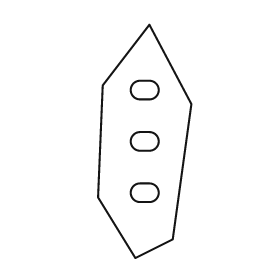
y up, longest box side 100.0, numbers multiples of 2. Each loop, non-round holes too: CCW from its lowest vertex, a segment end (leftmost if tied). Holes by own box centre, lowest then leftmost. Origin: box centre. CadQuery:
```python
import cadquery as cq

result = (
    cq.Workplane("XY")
    .moveTo(-4.0, -50.0)
    .lineTo(12.0, -42.0)
    .lineTo(20.0, 16.0)
    .lineTo(2.0, 50.0)
    .lineTo(-18.0, 24.0)
    .lineTo(-20.0, -24.0)
    .close()
    .moveTo(-2.0, -26.0)
    .lineTo(2.0, -26.0)
    .threePointArc((6.0, -22.0), (2.0, -18.0))
    .lineTo(-2.0, -18.0)
    .threePointArc((-6.0, -22.0), (-2.0, -26.0))
    .close()
    .moveTo(-2.0, -4.0)
    .lineTo(2.0, -4.0)
    .threePointArc((6.0, 0.0), (2.0, 4.0))
    .lineTo(-2.0, 4.0)
    .threePointArc((-6.0, 0.0), (-2.0, -4.0))
    .close()
    .moveTo(-2.0, 18.0)
    .lineTo(2.0, 18.0)
    .threePointArc((6.0, 22.0), (2.0, 26.0))
    .lineTo(-2.0, 26.0)
    .threePointArc((-6.0, 22.0), (-2.0, 18.0))
    .close()
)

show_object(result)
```